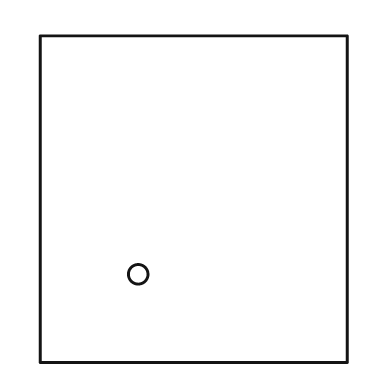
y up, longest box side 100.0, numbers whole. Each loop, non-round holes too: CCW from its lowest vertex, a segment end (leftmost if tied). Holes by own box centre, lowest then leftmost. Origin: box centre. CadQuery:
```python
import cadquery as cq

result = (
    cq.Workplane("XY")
    .moveTo(-47.0, -50.0)
    .lineTo(47.0, -50.0)
    .lineTo(47.0, 50.0)
    .lineTo(-47.0, 50.0)
    .close()
    .moveTo(-17.0, -23.0)
    .circle(3.0)
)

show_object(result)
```